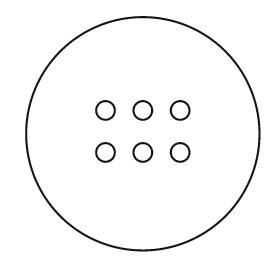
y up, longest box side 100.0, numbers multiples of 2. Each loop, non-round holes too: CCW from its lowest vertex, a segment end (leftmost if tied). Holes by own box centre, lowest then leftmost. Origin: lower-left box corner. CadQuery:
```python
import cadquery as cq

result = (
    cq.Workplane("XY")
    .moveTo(50.0, 50.0)
    .circle(50.0)
    .moveTo(34.0, 42.0)
    .circle(4.0)
    .moveTo(50.0, 42.0)
    .circle(4.0)
    .moveTo(66.0, 42.0)
    .circle(4.0)
    .moveTo(34.0, 60.0)
    .circle(4.0)
    .moveTo(50.0, 60.0)
    .circle(4.0)
    .moveTo(66.0, 60.0)
    .circle(4.0)
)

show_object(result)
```